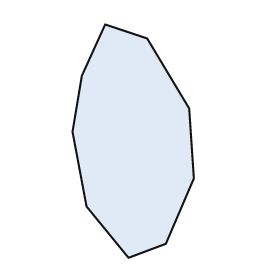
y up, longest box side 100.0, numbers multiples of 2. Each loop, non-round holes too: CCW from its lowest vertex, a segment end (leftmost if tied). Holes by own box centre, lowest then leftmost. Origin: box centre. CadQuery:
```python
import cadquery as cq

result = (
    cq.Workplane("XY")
    .moveTo(-2.0, -50.0)
    .lineTo(14.0, -44.0)
    .lineTo(26.0, -16.0)
    .lineTo(24.0, 14.0)
    .lineTo(6.0, 44.0)
    .lineTo(-12.0, 50.0)
    .lineTo(-22.0, 28.0)
    .lineTo(-26.0, 4.0)
    .lineTo(-20.0, -28.0)
    .close()
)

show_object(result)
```